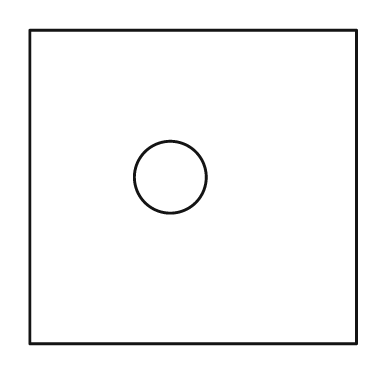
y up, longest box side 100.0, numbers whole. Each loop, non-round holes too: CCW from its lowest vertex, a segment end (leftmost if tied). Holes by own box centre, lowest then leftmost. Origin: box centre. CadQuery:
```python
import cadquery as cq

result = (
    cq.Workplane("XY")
    .moveTo(-50.0, -48.0)
    .lineTo(50.0, -48.0)
    .lineTo(50.0, 48.0)
    .lineTo(-50.0, 48.0)
    .close()
    .moveTo(-7.0, 3.0)
    .circle(11.0)
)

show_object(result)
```